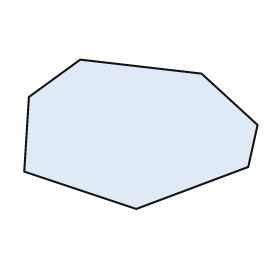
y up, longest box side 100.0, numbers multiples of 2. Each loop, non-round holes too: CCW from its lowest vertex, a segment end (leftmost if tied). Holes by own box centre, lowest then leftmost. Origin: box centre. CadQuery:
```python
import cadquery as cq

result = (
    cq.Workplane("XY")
    .moveTo(-2.0, -32.0)
    .lineTo(46.0, -14.0)
    .lineTo(50.0, 4.0)
    .lineTo(26.0, 26.0)
    .lineTo(-26.0, 32.0)
    .lineTo(-48.0, 16.0)
    .lineTo(-50.0, -16.0)
    .close()
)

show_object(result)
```